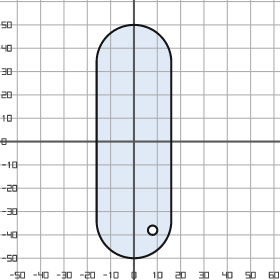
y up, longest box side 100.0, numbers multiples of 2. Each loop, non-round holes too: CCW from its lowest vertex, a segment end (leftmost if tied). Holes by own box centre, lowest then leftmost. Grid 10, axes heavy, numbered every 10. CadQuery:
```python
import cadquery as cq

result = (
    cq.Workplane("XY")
    .moveTo(-16.0, -34.0)
    .threePointArc((0.0, -50.0), (16.0, -34.0))
    .lineTo(16.0, 34.0)
    .threePointArc((0.0, 50.0), (-16.0, 34.0))
    .close()
    .moveTo(8.0, -38.0)
    .circle(2.0)
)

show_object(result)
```